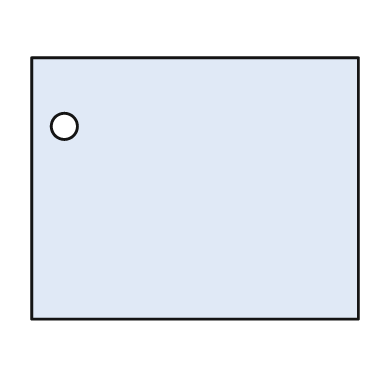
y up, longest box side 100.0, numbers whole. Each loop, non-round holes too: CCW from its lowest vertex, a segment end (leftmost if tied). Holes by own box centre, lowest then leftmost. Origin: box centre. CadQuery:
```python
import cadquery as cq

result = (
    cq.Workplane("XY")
    .moveTo(-50.0, -40.0)
    .lineTo(50.0, -40.0)
    .lineTo(50.0, 40.0)
    .lineTo(-50.0, 40.0)
    .close()
    .moveTo(-40.0, 19.0)
    .circle(4.0)
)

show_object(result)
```